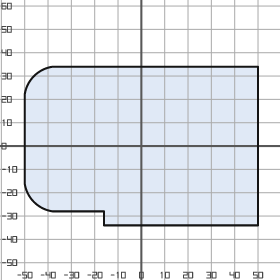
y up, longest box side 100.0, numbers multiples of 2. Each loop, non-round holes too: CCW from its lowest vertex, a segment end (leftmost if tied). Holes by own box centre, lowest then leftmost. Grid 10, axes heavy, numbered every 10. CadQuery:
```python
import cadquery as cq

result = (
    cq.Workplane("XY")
    .moveTo(-16.0, -34.0)
    .lineTo(50.0, -34.0)
    .lineTo(50.0, 34.0)
    .lineTo(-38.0, 34.0)
    .threePointArc((-46.0, 30.0), (-50.0, 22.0))
    .lineTo(-50.0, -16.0)
    .threePointArc((-46.0, -24.0), (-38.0, -28.0))
    .lineTo(-16.0, -28.0)
    .close()
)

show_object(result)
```